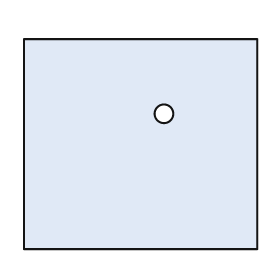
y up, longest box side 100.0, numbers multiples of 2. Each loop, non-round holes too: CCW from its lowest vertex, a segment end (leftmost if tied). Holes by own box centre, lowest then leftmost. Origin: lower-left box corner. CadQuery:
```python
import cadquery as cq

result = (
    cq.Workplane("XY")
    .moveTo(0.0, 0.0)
    .lineTo(100.0, 0.0)
    .lineTo(100.0, 90.0)
    .lineTo(0.0, 90.0)
    .close()
    .moveTo(60.0, 58.0)
    .circle(4.0)
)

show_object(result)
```